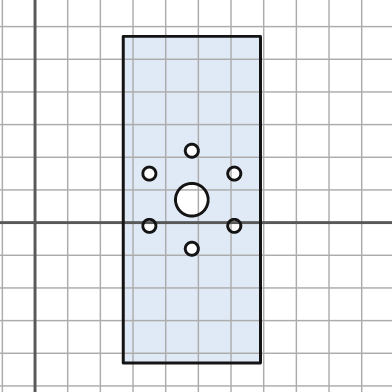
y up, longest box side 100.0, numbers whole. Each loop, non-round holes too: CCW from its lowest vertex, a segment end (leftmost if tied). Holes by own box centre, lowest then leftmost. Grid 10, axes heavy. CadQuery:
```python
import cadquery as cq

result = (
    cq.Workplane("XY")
    .moveTo(27.0, -43.0)
    .lineTo(69.0, -43.0)
    .lineTo(69.0, 57.0)
    .lineTo(27.0, 57.0)
    .close()
    .moveTo(48.0, -8.0)
    .circle(2.0)
    .moveTo(35.0, -1.0)
    .circle(2.0)
    .moveTo(61.0, -1.0)
    .circle(2.0)
    .moveTo(48.0, 7.0)
    .circle(5.0)
    .moveTo(35.0, 15.0)
    .circle(2.0)
    .moveTo(61.0, 15.0)
    .circle(2.0)
    .moveTo(48.0, 22.0)
    .circle(2.0)
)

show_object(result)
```